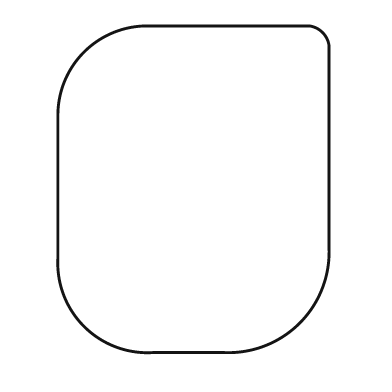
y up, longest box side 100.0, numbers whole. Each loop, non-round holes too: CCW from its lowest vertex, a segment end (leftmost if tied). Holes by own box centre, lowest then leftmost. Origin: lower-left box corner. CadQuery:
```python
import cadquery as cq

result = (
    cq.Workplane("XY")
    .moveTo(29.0, 0.0)
    .lineTo(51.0, 0.0)
    .threePointArc((74.0, 9.0), (83.0, 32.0))
    .lineTo(83.0, 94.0)
    .threePointArc((81.0, 98.0), (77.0, 100.0))
    .lineTo(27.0, 100.0)
    .threePointArc((8.0, 92.0), (0.0, 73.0))
    .lineTo(0.0, 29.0)
    .threePointArc((8.0, 8.0), (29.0, 0.0))
    .close()
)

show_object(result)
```